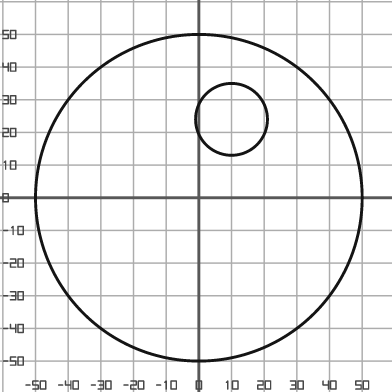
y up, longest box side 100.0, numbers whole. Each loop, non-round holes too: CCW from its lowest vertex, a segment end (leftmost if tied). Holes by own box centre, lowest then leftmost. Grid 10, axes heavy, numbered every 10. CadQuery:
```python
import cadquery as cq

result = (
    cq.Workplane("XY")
    .moveTo(0.0, 0.0)
    .circle(50.0)
    .moveTo(10.0, 24.0)
    .circle(11.0)
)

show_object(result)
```